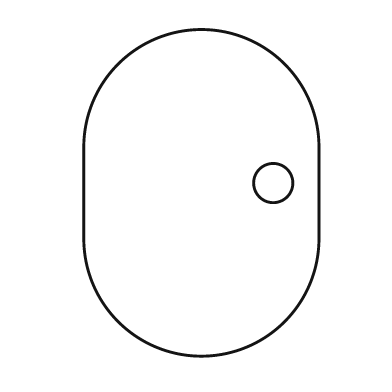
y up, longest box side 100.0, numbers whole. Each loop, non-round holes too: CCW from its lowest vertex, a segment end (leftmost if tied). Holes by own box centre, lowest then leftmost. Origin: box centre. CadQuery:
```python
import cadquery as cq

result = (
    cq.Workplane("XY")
    .moveTo(-36.0, -14.0)
    .threePointArc((0.0, -50.0), (36.0, -14.0))
    .lineTo(36.0, 14.0)
    .threePointArc((0.0, 50.0), (-36.0, 14.0))
    .close()
    .moveTo(22.0, 3.0)
    .circle(6.0)
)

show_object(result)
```